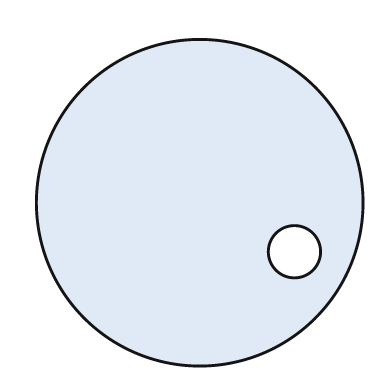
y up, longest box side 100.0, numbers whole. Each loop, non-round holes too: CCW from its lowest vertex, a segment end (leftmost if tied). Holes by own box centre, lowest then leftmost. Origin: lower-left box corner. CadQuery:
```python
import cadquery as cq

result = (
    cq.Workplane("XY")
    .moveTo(50.0, 50.0)
    .circle(50.0)
    .moveTo(79.0, 35.0)
    .circle(8.0)
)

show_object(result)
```